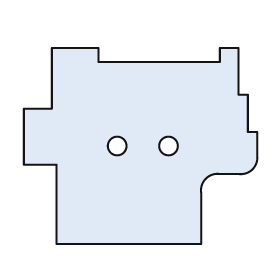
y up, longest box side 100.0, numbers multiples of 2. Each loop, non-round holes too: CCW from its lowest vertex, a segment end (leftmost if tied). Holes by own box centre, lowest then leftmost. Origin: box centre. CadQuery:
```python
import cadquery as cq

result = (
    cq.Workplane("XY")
    .moveTo(-36.0, -42.0)
    .lineTo(26.0, -42.0)
    .lineTo(26.0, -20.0)
    .threePointArc((28.0, -14.0), (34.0, -12.0))
    .lineTo(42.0, -12.0)
    .threePointArc((48.0, -10.0), (50.0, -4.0))
    .lineTo(50.0, 6.0)
    .lineTo(46.0, 6.0)
    .lineTo(46.0, 22.0)
    .lineTo(42.0, 22.0)
    .lineTo(42.0, 42.0)
    .lineTo(34.0, 42.0)
    .lineTo(34.0, 36.0)
    .lineTo(-18.0, 36.0)
    .lineTo(-18.0, 42.0)
    .lineTo(-38.0, 42.0)
    .lineTo(-38.0, 16.0)
    .lineTo(-50.0, 16.0)
    .lineTo(-50.0, -8.0)
    .lineTo(-36.0, -8.0)
    .close()
    .moveTo(-10.0, 0.0)
    .circle(4.0)
    .moveTo(12.0, 0.0)
    .circle(4.0)
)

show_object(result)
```